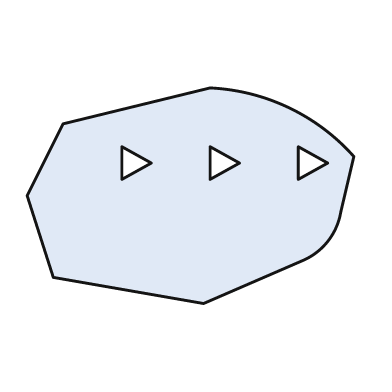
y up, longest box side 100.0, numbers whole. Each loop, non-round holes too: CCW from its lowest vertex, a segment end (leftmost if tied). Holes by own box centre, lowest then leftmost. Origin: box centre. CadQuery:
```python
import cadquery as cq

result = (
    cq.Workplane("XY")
    .moveTo(4.0, -33.0)
    .lineTo(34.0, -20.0)
    .threePointArc((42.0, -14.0), (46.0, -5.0))
    .lineTo(50.0, 12.0)
    .threePointArc((30.0, 27.0), (6.0, 33.0))
    .lineTo(-39.0, 22.0)
    .lineTo(-50.0, 0.0)
    .lineTo(-42.0, -25.0)
    .close()
    .moveTo(-21.0, 5.0)
    .lineTo(-12.0, 10.0)
    .lineTo(-21.0, 15.0)
    .close()
    .moveTo(6.0, 5.0)
    .lineTo(15.0, 10.0)
    .lineTo(6.0, 15.0)
    .close()
    .moveTo(33.0, 5.0)
    .lineTo(42.0, 10.0)
    .lineTo(33.0, 15.0)
    .close()
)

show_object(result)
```